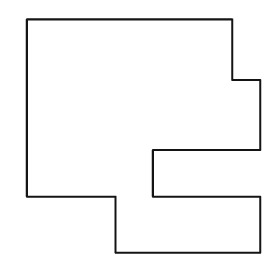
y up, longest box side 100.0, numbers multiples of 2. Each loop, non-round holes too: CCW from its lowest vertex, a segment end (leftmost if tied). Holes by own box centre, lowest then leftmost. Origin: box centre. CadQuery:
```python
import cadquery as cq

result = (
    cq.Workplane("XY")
    .moveTo(-12.0, -50.0)
    .lineTo(50.0, -50.0)
    .lineTo(50.0, -26.0)
    .lineTo(4.0, -26.0)
    .lineTo(4.0, -6.0)
    .lineTo(50.0, -6.0)
    .lineTo(50.0, 24.0)
    .lineTo(38.0, 24.0)
    .lineTo(38.0, 50.0)
    .lineTo(-50.0, 50.0)
    .lineTo(-50.0, -26.0)
    .lineTo(-12.0, -26.0)
    .close()
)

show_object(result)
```